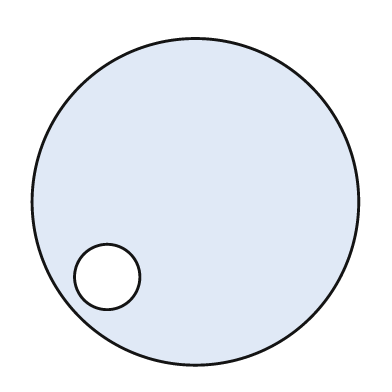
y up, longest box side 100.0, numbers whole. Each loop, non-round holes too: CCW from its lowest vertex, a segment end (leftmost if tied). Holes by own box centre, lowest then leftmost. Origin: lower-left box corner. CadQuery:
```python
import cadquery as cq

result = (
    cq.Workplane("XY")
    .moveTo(50.0, 50.0)
    .circle(50.0)
    .moveTo(23.0, 27.0)
    .circle(10.0)
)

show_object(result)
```